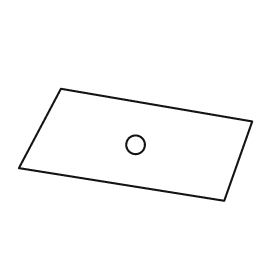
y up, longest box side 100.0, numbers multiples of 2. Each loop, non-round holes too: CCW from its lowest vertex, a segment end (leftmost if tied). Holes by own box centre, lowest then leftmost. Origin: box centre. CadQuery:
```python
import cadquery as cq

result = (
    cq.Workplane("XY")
    .moveTo(38.0, -24.0)
    .lineTo(50.0, 10.0)
    .lineTo(-32.0, 24.0)
    .lineTo(-50.0, -10.0)
    .close()
    .moveTo(0.0, 0.0)
    .circle(4.0)
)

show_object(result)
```